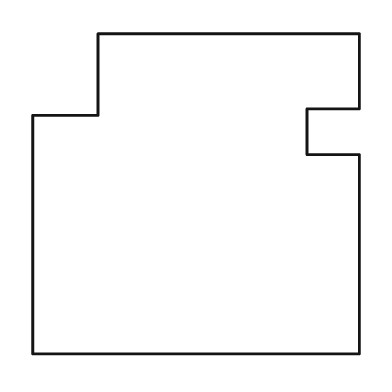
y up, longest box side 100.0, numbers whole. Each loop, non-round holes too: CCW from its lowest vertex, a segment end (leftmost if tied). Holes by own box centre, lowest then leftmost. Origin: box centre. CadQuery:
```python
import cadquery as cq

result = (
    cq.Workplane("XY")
    .moveTo(-50.0, -49.0)
    .lineTo(50.0, -49.0)
    .lineTo(50.0, 12.0)
    .lineTo(34.0, 12.0)
    .lineTo(34.0, 26.0)
    .lineTo(50.0, 26.0)
    .lineTo(50.0, 49.0)
    .lineTo(-30.0, 49.0)
    .lineTo(-30.0, 24.0)
    .lineTo(-50.0, 24.0)
    .close()
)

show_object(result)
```